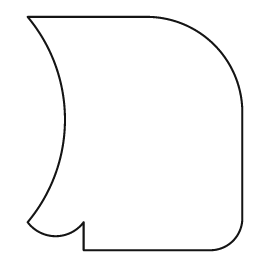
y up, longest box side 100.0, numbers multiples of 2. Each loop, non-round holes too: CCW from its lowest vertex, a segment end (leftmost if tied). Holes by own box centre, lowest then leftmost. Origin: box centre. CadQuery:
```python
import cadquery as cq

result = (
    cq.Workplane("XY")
    .moveTo(-22.0, -50.0)
    .lineTo(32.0, -50.0)
    .threePointArc((42.0, -46.0), (46.0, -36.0))
    .lineTo(46.0, 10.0)
    .threePointArc((34.0, 38.0), (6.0, 50.0))
    .lineTo(-46.0, 50.0)
    .threePointArc((-30.0, 6.0), (-46.0, -38.0))
    .threePointArc((-34.0, -44.0), (-22.0, -38.0))
    .close()
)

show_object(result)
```